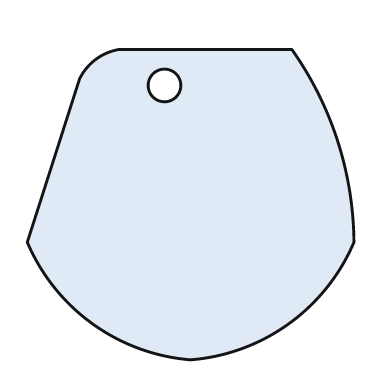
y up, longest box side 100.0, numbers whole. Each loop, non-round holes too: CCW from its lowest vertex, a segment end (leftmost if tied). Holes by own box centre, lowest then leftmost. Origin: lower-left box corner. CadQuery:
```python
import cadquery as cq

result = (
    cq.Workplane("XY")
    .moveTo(50.0, 0.0)
    .threePointArc((80.0, 11.0), (100.0, 36.0))
    .threePointArc((95.0, 67.0), (81.0, 95.0))
    .lineTo(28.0, 95.0)
    .threePointArc((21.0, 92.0), (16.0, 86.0))
    .lineTo(0.0, 36.0)
    .threePointArc((20.0, 11.0), (50.0, 0.0))
    .close()
    .moveTo(42.0, 84.0)
    .circle(5.0)
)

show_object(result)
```